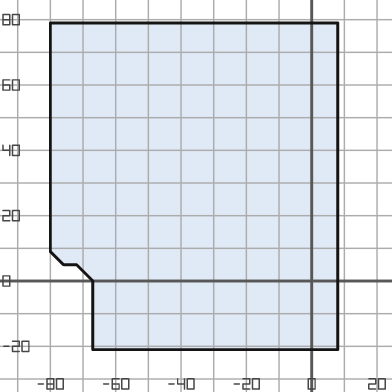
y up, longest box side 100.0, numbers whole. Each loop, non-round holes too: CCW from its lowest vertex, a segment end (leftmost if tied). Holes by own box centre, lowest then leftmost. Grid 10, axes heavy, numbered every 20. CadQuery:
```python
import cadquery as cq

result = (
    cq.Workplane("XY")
    .moveTo(-67.0, -21.0)
    .lineTo(8.0, -21.0)
    .lineTo(8.0, 79.0)
    .lineTo(-80.0, 79.0)
    .lineTo(-80.0, 9.0)
    .lineTo(-76.0, 5.0)
    .lineTo(-72.0, 5.0)
    .lineTo(-67.0, 0.0)
    .close()
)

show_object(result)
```